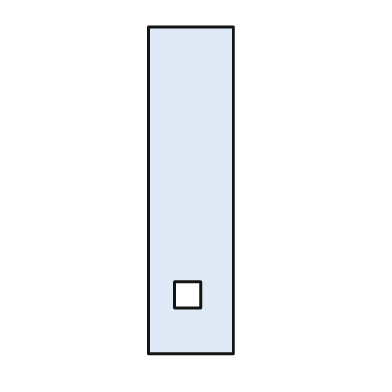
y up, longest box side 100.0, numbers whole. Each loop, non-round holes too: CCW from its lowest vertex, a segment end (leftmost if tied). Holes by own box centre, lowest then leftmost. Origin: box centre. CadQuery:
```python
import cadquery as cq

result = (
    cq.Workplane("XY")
    .moveTo(-13.0, -50.0)
    .lineTo(13.0, -50.0)
    .lineTo(13.0, 50.0)
    .lineTo(-13.0, 50.0)
    .close()
    .moveTo(-5.0, -36.0)
    .lineTo(3.0, -36.0)
    .lineTo(3.0, -28.0)
    .lineTo(-5.0, -28.0)
    .close()
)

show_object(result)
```